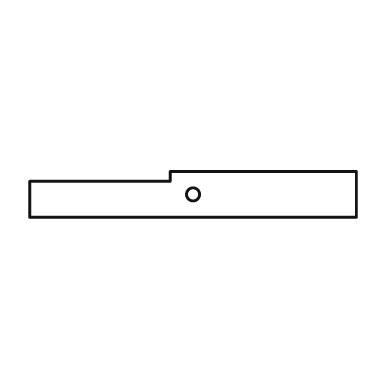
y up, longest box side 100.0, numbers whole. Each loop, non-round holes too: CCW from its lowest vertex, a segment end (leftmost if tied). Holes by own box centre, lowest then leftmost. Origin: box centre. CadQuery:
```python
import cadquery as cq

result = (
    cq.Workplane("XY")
    .moveTo(-50.0, -7.0)
    .lineTo(50.0, -7.0)
    .lineTo(50.0, 7.0)
    .lineTo(-7.0, 7.0)
    .lineTo(-7.0, 4.0)
    .lineTo(-50.0, 4.0)
    .close()
    .moveTo(0.0, 0.0)
    .circle(2.0)
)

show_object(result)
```